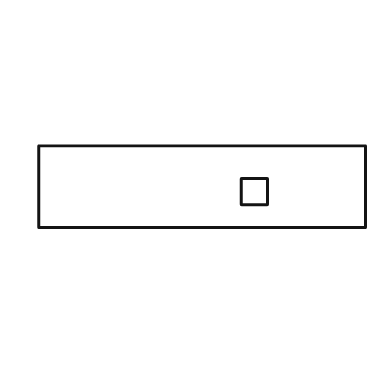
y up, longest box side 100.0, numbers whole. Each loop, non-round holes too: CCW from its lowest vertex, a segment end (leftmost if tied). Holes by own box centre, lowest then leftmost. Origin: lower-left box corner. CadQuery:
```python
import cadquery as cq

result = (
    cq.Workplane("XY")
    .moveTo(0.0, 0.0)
    .lineTo(100.0, 0.0)
    .lineTo(100.0, 25.0)
    .lineTo(0.0, 25.0)
    .close()
    .moveTo(62.0, 7.0)
    .lineTo(70.0, 7.0)
    .lineTo(70.0, 15.0)
    .lineTo(62.0, 15.0)
    .close()
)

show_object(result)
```